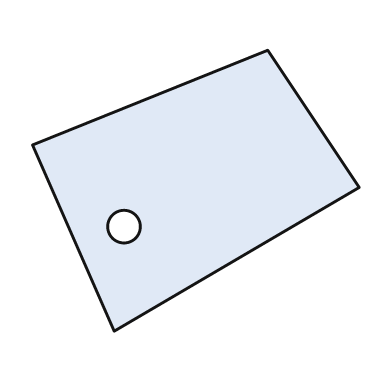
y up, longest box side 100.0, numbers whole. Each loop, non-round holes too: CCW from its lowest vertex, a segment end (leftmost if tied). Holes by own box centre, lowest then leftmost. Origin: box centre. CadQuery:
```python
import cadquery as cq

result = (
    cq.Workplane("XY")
    .moveTo(-25.0, -43.0)
    .lineTo(50.0, 1.0)
    .lineTo(22.0, 43.0)
    .lineTo(-50.0, 14.0)
    .close()
    .moveTo(-22.0, -11.0)
    .circle(5.0)
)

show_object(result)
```